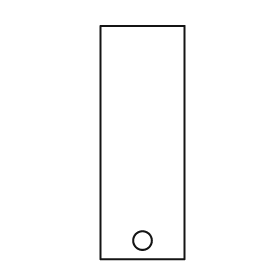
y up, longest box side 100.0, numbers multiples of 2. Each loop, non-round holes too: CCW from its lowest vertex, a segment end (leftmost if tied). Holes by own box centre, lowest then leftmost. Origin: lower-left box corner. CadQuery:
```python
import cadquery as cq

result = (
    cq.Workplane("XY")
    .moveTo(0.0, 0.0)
    .lineTo(36.0, 0.0)
    .lineTo(36.0, 100.0)
    .lineTo(0.0, 100.0)
    .close()
    .moveTo(18.0, 8.0)
    .circle(4.0)
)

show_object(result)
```